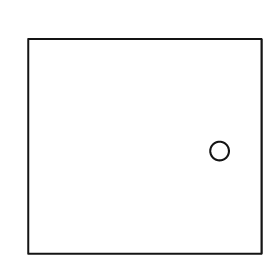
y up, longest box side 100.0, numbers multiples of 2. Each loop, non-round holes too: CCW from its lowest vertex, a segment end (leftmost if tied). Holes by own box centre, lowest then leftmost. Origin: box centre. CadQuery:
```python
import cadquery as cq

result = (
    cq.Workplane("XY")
    .moveTo(-50.0, -46.0)
    .lineTo(50.0, -46.0)
    .lineTo(50.0, 46.0)
    .lineTo(-50.0, 46.0)
    .close()
    .moveTo(32.0, -2.0)
    .circle(4.0)
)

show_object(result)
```